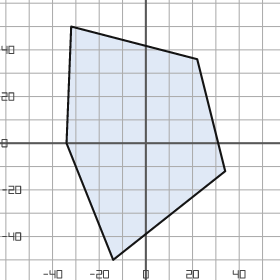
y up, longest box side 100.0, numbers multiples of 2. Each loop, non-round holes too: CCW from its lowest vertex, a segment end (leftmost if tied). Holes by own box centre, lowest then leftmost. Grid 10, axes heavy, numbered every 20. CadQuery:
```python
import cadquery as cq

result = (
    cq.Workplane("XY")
    .moveTo(-14.0, -50.0)
    .lineTo(34.0, -12.0)
    .lineTo(22.0, 36.0)
    .lineTo(-32.0, 50.0)
    .lineTo(-34.0, 0.0)
    .close()
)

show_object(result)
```